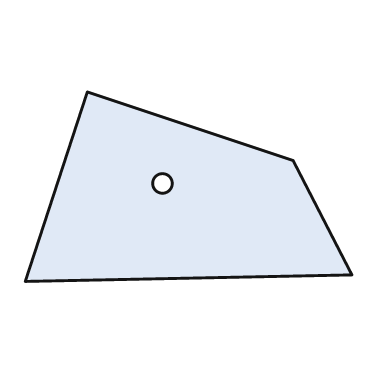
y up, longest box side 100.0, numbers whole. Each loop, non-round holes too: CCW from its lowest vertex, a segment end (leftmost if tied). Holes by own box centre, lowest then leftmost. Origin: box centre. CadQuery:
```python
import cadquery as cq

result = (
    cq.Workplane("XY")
    .moveTo(-50.0, -29.0)
    .lineTo(50.0, -27.0)
    .lineTo(32.0, 8.0)
    .lineTo(-31.0, 29.0)
    .close()
    .moveTo(-8.0, 1.0)
    .circle(3.0)
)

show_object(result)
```